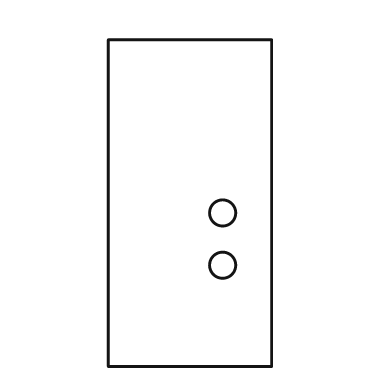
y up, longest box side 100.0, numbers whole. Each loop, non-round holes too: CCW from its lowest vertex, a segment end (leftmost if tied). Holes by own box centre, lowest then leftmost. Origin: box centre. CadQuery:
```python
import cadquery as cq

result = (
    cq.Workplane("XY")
    .moveTo(-25.0, -50.0)
    .lineTo(25.0, -50.0)
    .lineTo(25.0, 50.0)
    .lineTo(-25.0, 50.0)
    .close()
    .moveTo(10.0, -19.0)
    .circle(4.0)
    .moveTo(10.0, -3.0)
    .circle(4.0)
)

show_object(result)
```